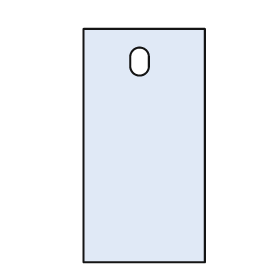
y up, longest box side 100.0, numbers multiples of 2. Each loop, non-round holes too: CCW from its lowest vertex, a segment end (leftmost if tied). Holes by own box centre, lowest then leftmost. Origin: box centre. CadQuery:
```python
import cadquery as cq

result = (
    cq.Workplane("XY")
    .moveTo(-26.0, -50.0)
    .lineTo(26.0, -50.0)
    .lineTo(26.0, 50.0)
    .lineTo(-26.0, 50.0)
    .close()
    .moveTo(-6.0, 34.0)
    .threePointArc((-2.0, 30.0), (2.0, 34.0))
    .lineTo(2.0, 38.0)
    .threePointArc((-2.0, 42.0), (-6.0, 38.0))
    .close()
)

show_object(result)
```